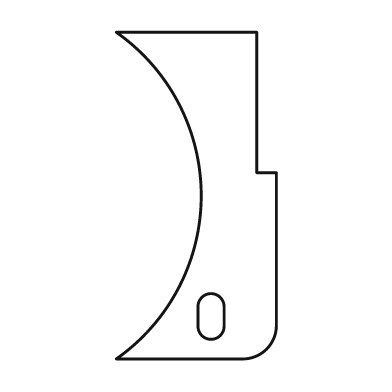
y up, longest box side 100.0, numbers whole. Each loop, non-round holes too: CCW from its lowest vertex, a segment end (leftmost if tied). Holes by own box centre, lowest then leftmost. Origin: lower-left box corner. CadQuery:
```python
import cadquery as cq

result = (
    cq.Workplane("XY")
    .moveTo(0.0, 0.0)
    .lineTo(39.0, 0.0)
    .threePointArc((46.0, 3.0), (49.0, 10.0))
    .lineTo(49.0, 57.0)
    .lineTo(43.0, 57.0)
    .lineTo(43.0, 100.0)
    .lineTo(0.0, 100.0)
    .threePointArc((26.0, 50.0), (0.0, 0.0))
    .close()
    .moveTo(25.0, 10.0)
    .threePointArc((29.0, 6.0), (33.0, 10.0))
    .lineTo(33.0, 16.0)
    .threePointArc((29.0, 20.0), (25.0, 16.0))
    .close()
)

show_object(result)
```